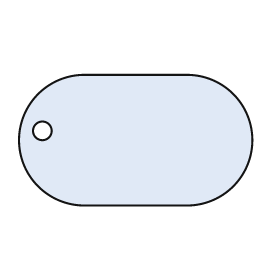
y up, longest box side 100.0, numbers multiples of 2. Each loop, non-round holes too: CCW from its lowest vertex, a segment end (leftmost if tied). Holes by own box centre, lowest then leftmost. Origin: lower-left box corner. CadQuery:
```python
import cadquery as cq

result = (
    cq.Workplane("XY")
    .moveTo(28.0, 0.0)
    .lineTo(72.0, 0.0)
    .threePointArc((100.0, 28.0), (72.0, 56.0))
    .lineTo(28.0, 56.0)
    .threePointArc((0.0, 28.0), (28.0, 0.0))
    .close()
    .moveTo(10.0, 32.0)
    .circle(4.0)
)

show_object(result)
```